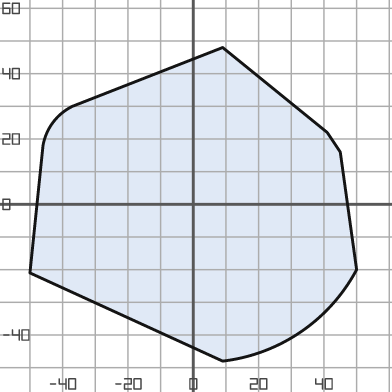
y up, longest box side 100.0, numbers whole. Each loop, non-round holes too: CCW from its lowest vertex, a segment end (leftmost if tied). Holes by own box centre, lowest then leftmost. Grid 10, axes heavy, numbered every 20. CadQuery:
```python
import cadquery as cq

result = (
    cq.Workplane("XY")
    .moveTo(9.0, -48.0)
    .threePointArc((33.0, -39.0), (50.0, -20.0))
    .lineTo(45.0, 16.0)
    .lineTo(41.0, 22.0)
    .lineTo(9.0, 48.0)
    .lineTo(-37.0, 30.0)
    .threePointArc((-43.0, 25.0), (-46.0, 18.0))
    .lineTo(-50.0, -21.0)
    .close()
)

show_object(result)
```